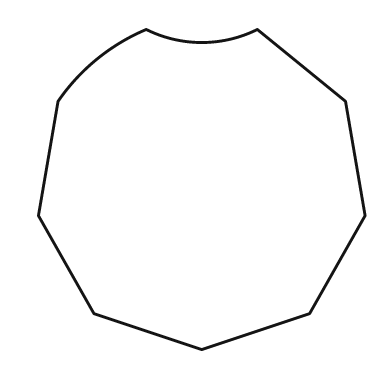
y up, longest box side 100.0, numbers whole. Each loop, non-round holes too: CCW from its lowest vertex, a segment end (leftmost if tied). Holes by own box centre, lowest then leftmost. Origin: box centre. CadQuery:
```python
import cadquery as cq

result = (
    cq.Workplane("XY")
    .moveTo(0.0, -49.0)
    .lineTo(33.0, -38.0)
    .lineTo(50.0, -8.0)
    .lineTo(44.0, 27.0)
    .lineTo(17.0, 49.0)
    .threePointArc((0.0, 45.0), (-17.0, 49.0))
    .threePointArc((-32.0, 40.0), (-44.0, 27.0))
    .lineTo(-50.0, -8.0)
    .lineTo(-33.0, -38.0)
    .close()
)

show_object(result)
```